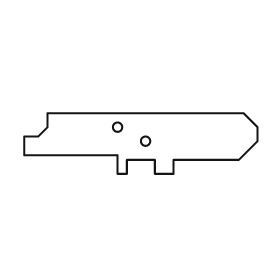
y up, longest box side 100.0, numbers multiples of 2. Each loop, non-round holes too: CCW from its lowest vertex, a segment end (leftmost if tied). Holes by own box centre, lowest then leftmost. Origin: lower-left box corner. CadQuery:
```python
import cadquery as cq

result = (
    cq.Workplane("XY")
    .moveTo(40.0, 0.0)
    .lineTo(44.0, 0.0)
    .lineTo(44.0, 6.0)
    .lineTo(56.0, 6.0)
    .lineTo(56.0, 0.0)
    .lineTo(64.0, 0.0)
    .lineTo(64.0, 6.0)
    .lineTo(92.0, 6.0)
    .lineTo(100.0, 14.0)
    .lineTo(100.0, 20.0)
    .lineTo(94.0, 26.0)
    .lineTo(10.0, 26.0)
    .lineTo(10.0, 20.0)
    .lineTo(6.0, 16.0)
    .lineTo(0.0, 16.0)
    .lineTo(0.0, 8.0)
    .lineTo(40.0, 8.0)
    .close()
    .moveTo(52.0, 14.0)
    .circle(2.0)
    .moveTo(40.0, 20.0)
    .circle(2.0)
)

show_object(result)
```